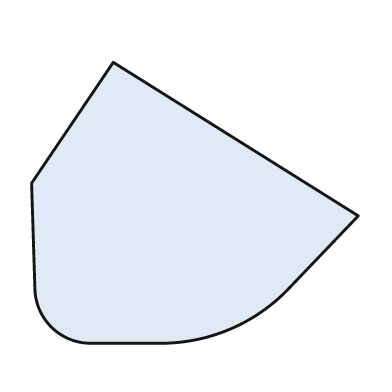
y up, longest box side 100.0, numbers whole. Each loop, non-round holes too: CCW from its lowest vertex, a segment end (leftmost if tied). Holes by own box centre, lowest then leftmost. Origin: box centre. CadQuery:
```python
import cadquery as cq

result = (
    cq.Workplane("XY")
    .moveTo(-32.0, -43.0)
    .lineTo(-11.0, -43.0)
    .threePointArc((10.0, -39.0), (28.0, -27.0))
    .lineTo(50.0, -4.0)
    .lineTo(-25.0, 43.0)
    .lineTo(-50.0, 6.0)
    .lineTo(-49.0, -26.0)
    .threePointArc((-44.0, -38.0), (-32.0, -43.0))
    .close()
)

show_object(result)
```